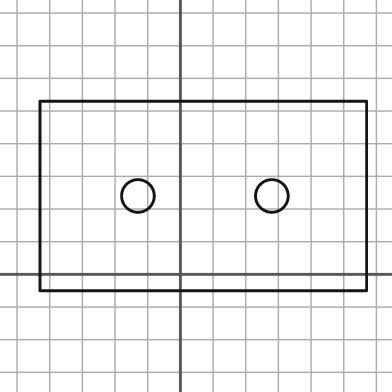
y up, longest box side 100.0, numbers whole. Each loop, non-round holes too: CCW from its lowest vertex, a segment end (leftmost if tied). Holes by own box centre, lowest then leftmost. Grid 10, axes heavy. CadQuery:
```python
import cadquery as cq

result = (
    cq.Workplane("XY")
    .moveTo(-43.0, -5.0)
    .lineTo(57.0, -5.0)
    .lineTo(57.0, 53.0)
    .lineTo(-43.0, 53.0)
    .close()
    .moveTo(-13.0, 24.0)
    .circle(5.0)
    .moveTo(28.0, 24.0)
    .circle(5.0)
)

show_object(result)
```